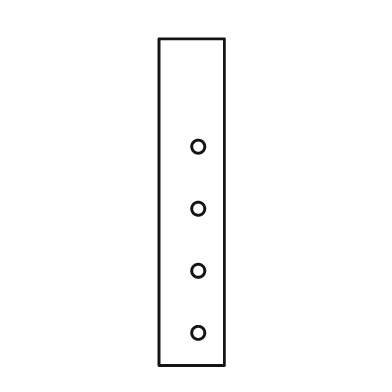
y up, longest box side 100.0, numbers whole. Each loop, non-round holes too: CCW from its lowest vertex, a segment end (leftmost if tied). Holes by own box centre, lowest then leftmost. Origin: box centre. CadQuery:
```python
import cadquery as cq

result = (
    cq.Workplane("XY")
    .moveTo(-10.0, -50.0)
    .lineTo(10.0, -50.0)
    .lineTo(10.0, 50.0)
    .lineTo(-10.0, 50.0)
    .close()
    .moveTo(2.0, -40.0)
    .circle(2.0)
    .moveTo(2.0, -21.0)
    .circle(2.0)
    .moveTo(2.0, -2.0)
    .circle(2.0)
    .moveTo(2.0, 17.0)
    .circle(2.0)
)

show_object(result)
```